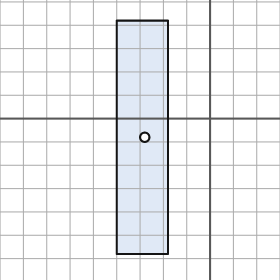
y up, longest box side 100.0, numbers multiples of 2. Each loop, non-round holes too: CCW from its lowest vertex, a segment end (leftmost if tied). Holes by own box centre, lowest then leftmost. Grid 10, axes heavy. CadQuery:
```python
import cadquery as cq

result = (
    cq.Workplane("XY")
    .moveTo(-40.0, -58.0)
    .lineTo(-18.0, -58.0)
    .lineTo(-18.0, 42.0)
    .lineTo(-40.0, 42.0)
    .close()
    .moveTo(-28.0, -8.0)
    .circle(2.0)
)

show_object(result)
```